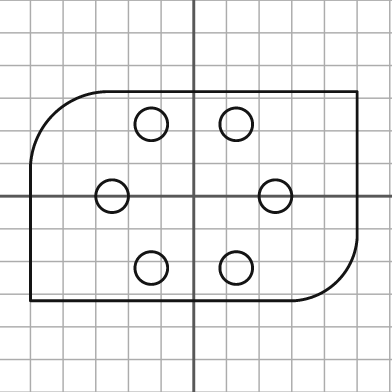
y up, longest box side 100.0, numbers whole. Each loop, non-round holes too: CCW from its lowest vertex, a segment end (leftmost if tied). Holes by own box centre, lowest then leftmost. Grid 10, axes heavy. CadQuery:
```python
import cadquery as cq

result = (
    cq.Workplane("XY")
    .moveTo(-50.0, -32.0)
    .lineTo(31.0, -32.0)
    .threePointArc((44.0, -26.0), (50.0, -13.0))
    .lineTo(50.0, 32.0)
    .lineTo(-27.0, 32.0)
    .threePointArc((-43.0, 25.0), (-50.0, 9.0))
    .close()
    .moveTo(-13.0, -22.0)
    .circle(5.0)
    .moveTo(13.0, -22.0)
    .circle(5.0)
    .moveTo(-25.0, 0.0)
    .circle(5.0)
    .moveTo(25.0, 0.0)
    .circle(5.0)
    .moveTo(-13.0, 22.0)
    .circle(5.0)
    .moveTo(13.0, 22.0)
    .circle(5.0)
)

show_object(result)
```